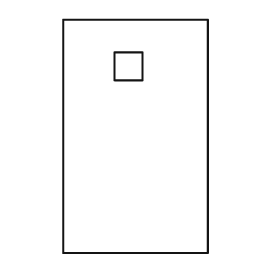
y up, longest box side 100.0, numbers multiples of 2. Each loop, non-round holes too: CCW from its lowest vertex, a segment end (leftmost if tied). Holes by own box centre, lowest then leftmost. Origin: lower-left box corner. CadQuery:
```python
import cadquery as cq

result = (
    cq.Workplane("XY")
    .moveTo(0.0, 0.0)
    .lineTo(62.0, 0.0)
    .lineTo(62.0, 100.0)
    .lineTo(0.0, 100.0)
    .close()
    .moveTo(22.0, 74.0)
    .lineTo(34.0, 74.0)
    .lineTo(34.0, 86.0)
    .lineTo(22.0, 86.0)
    .close()
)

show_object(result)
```